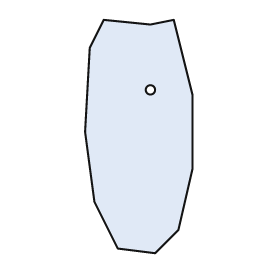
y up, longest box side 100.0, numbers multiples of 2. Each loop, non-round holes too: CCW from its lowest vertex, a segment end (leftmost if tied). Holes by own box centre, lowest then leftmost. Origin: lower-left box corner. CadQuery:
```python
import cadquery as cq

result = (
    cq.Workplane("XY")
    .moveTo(30.0, 0.0)
    .lineTo(40.0, 10.0)
    .lineTo(46.0, 36.0)
    .lineTo(46.0, 68.0)
    .lineTo(38.0, 100.0)
    .lineTo(28.0, 98.0)
    .lineTo(8.0, 100.0)
    .lineTo(2.0, 88.0)
    .lineTo(0.0, 52.0)
    .lineTo(4.0, 22.0)
    .lineTo(14.0, 2.0)
    .close()
    .moveTo(28.0, 70.0)
    .circle(2.0)
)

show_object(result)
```